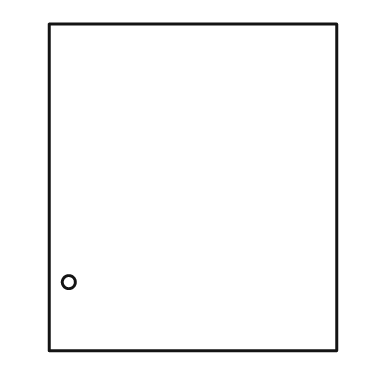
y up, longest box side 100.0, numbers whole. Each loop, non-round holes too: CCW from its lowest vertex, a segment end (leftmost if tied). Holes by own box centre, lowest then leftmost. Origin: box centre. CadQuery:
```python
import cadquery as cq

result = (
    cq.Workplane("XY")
    .moveTo(-44.0, -50.0)
    .lineTo(44.0, -50.0)
    .lineTo(44.0, 50.0)
    .lineTo(-44.0, 50.0)
    .close()
    .moveTo(-38.0, -29.0)
    .circle(2.0)
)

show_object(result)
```